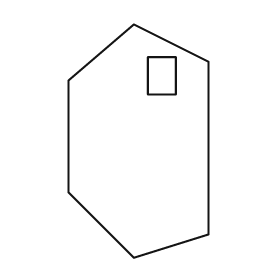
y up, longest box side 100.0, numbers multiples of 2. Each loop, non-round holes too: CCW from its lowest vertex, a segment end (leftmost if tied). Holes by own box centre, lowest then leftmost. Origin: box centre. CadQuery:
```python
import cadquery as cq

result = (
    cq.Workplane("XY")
    .moveTo(-2.0, -50.0)
    .lineTo(30.0, -40.0)
    .lineTo(30.0, 34.0)
    .lineTo(-2.0, 50.0)
    .lineTo(-30.0, 26.0)
    .lineTo(-30.0, -22.0)
    .close()
    .moveTo(4.0, 20.0)
    .lineTo(16.0, 20.0)
    .lineTo(16.0, 36.0)
    .lineTo(4.0, 36.0)
    .close()
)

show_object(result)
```